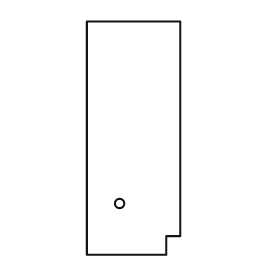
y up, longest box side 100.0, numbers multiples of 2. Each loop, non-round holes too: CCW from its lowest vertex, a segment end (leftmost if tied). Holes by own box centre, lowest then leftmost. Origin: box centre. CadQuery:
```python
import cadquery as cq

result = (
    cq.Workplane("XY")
    .moveTo(-20.0, -50.0)
    .lineTo(14.0, -50.0)
    .lineTo(14.0, -42.0)
    .lineTo(20.0, -42.0)
    .lineTo(20.0, 50.0)
    .lineTo(-20.0, 50.0)
    .close()
    .moveTo(-6.0, -28.0)
    .circle(2.0)
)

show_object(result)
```